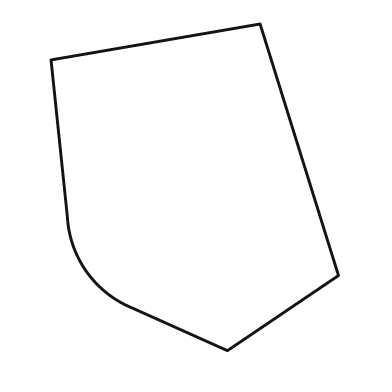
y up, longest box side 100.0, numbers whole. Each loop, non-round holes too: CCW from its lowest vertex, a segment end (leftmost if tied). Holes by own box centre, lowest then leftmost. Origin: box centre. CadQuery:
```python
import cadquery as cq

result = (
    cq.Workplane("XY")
    .moveTo(10.0, -50.0)
    .lineTo(44.0, -27.0)
    .lineTo(20.0, 50.0)
    .lineTo(-44.0, 39.0)
    .lineTo(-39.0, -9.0)
    .threePointArc((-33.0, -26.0), (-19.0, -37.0))
    .close()
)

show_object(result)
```